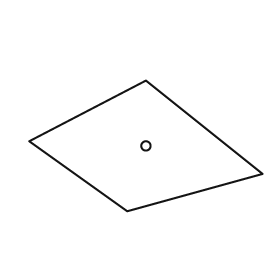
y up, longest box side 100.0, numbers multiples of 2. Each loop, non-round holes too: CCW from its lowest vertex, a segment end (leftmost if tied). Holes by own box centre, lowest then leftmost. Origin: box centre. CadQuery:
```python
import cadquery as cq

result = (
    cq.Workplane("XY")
    .moveTo(-8.0, -28.0)
    .lineTo(50.0, -12.0)
    .lineTo(0.0, 28.0)
    .lineTo(-50.0, 2.0)
    .close()
    .moveTo(0.0, 0.0)
    .circle(2.0)
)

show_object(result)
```